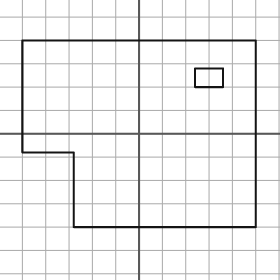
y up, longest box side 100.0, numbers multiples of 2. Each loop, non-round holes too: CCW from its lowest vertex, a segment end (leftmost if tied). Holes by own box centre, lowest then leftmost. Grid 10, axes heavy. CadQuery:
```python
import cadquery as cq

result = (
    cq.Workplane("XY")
    .moveTo(-28.0, -40.0)
    .lineTo(50.0, -40.0)
    .lineTo(50.0, 40.0)
    .lineTo(-50.0, 40.0)
    .lineTo(-50.0, -8.0)
    .lineTo(-28.0, -8.0)
    .close()
    .moveTo(24.0, 20.0)
    .lineTo(36.0, 20.0)
    .lineTo(36.0, 28.0)
    .lineTo(24.0, 28.0)
    .close()
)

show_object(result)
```